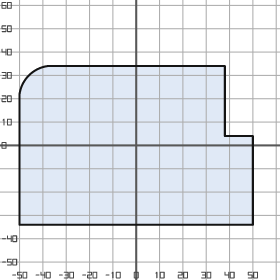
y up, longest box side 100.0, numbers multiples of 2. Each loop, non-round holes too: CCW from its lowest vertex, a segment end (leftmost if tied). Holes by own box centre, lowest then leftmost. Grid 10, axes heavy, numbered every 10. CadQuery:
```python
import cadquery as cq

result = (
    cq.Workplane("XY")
    .moveTo(-50.0, -34.0)
    .lineTo(50.0, -34.0)
    .lineTo(50.0, 4.0)
    .lineTo(38.0, 4.0)
    .lineTo(38.0, 34.0)
    .lineTo(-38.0, 34.0)
    .threePointArc((-46.0, 30.0), (-50.0, 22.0))
    .close()
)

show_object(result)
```